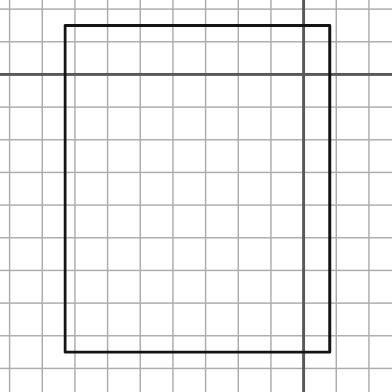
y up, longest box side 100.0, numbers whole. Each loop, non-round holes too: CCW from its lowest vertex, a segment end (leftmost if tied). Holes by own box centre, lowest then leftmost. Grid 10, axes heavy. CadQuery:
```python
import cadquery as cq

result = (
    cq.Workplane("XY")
    .moveTo(-73.0, -85.0)
    .lineTo(8.0, -85.0)
    .lineTo(8.0, 15.0)
    .lineTo(-73.0, 15.0)
    .close()
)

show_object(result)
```